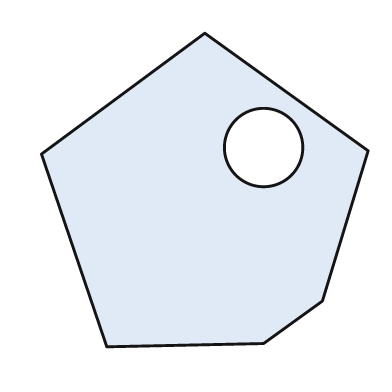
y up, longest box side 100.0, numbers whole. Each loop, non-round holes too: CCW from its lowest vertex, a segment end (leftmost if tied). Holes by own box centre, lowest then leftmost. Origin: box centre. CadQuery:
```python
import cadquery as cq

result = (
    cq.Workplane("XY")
    .moveTo(-30.0, -48.0)
    .lineTo(18.0, -47.0)
    .lineTo(36.0, -34.0)
    .lineTo(50.0, 12.0)
    .lineTo(0.0, 48.0)
    .lineTo(-50.0, 11.0)
    .close()
    .moveTo(18.0, 13.0)
    .circle(12.0)
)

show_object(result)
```